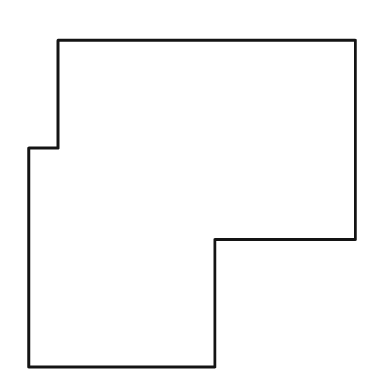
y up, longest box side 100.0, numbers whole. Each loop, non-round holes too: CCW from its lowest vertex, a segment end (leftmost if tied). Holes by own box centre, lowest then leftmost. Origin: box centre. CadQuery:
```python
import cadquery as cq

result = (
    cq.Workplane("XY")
    .moveTo(-50.0, -50.0)
    .lineTo(7.0, -50.0)
    .lineTo(7.0, -11.0)
    .lineTo(50.0, -11.0)
    .lineTo(50.0, 50.0)
    .lineTo(-41.0, 50.0)
    .lineTo(-41.0, 17.0)
    .lineTo(-50.0, 17.0)
    .close()
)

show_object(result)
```